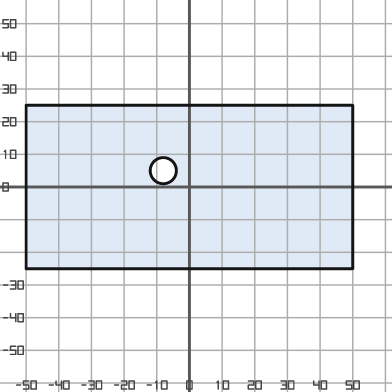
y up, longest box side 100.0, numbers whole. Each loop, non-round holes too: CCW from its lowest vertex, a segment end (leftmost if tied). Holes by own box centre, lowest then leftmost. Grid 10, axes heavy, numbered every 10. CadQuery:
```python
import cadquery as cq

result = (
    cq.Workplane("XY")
    .moveTo(-50.0, -25.0)
    .lineTo(50.0, -25.0)
    .lineTo(50.0, 25.0)
    .lineTo(-50.0, 25.0)
    .close()
    .moveTo(-8.0, 5.0)
    .circle(4.0)
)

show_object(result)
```